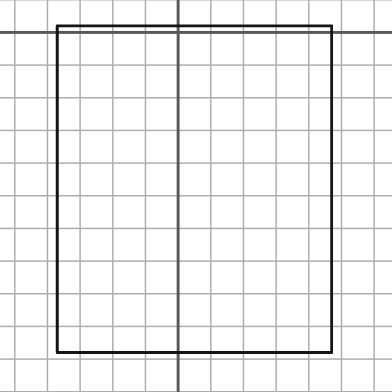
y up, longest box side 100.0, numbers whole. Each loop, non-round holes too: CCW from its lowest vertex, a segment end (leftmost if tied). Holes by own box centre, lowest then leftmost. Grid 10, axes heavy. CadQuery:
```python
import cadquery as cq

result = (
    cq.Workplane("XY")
    .moveTo(-37.0, -98.0)
    .lineTo(47.0, -98.0)
    .lineTo(47.0, 2.0)
    .lineTo(-37.0, 2.0)
    .close()
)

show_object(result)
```